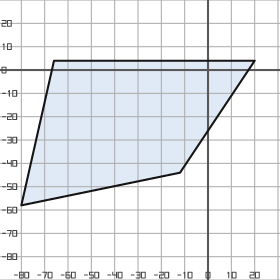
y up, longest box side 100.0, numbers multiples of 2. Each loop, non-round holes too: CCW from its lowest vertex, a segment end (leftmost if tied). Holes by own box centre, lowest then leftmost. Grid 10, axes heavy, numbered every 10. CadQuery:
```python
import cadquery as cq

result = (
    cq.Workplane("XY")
    .moveTo(-80.0, -58.0)
    .lineTo(-12.0, -44.0)
    .lineTo(20.0, 4.0)
    .lineTo(-66.0, 4.0)
    .close()
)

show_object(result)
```